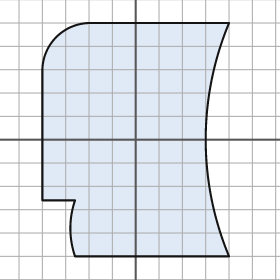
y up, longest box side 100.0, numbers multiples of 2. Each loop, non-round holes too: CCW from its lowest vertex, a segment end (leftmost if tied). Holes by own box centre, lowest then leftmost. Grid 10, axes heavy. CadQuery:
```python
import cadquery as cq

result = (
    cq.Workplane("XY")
    .moveTo(-26.0, -50.0)
    .lineTo(40.0, -50.0)
    .threePointArc((30.0, 0.0), (40.0, 50.0))
    .lineTo(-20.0, 50.0)
    .threePointArc((-34.0, 44.0), (-40.0, 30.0))
    .lineTo(-40.0, -26.0)
    .lineTo(-26.0, -26.0)
    .threePointArc((-28.0, -38.0), (-26.0, -50.0))
    .close()
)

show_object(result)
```